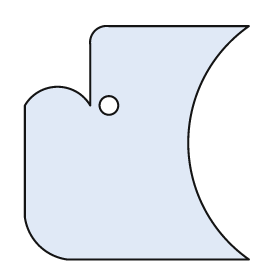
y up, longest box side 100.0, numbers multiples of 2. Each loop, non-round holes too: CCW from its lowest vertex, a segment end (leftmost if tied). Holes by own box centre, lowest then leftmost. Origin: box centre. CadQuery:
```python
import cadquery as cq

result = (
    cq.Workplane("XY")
    .moveTo(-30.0, -50.0)
    .lineTo(48.0, -50.0)
    .threePointArc((22.0, 0.0), (48.0, 50.0))
    .lineTo(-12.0, 50.0)
    .threePointArc((-18.0, 48.0), (-20.0, 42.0))
    .lineTo(-20.0, 16.0)
    .threePointArc((-34.0, 24.0), (-48.0, 16.0))
    .lineTo(-48.0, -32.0)
    .threePointArc((-42.0, -44.0), (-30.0, -50.0))
    .close()
    .moveTo(-12.0, 16.0)
    .circle(4.0)
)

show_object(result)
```